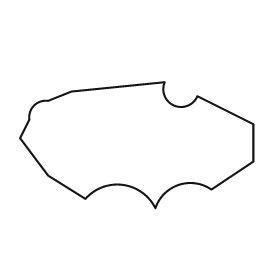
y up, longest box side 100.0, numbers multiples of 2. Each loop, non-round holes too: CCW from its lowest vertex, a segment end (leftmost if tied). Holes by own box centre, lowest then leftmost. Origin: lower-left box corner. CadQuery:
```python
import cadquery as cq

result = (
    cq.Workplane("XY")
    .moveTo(58.0, 0.0)
    .threePointArc((68.0, 10.0), (82.0, 8.0))
    .lineTo(100.0, 20.0)
    .lineTo(100.0, 36.0)
    .lineTo(76.0, 48.0)
    .threePointArc((66.0, 44.0), (62.0, 54.0))
    .lineTo(22.0, 50.0)
    .lineTo(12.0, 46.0)
    .threePointArc((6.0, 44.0), (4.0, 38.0))
    .lineTo(0.0, 30.0)
    .lineTo(12.0, 14.0)
    .lineTo(28.0, 4.0)
    .threePointArc((44.0, 10.0), (58.0, 0.0))
    .close()
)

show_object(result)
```